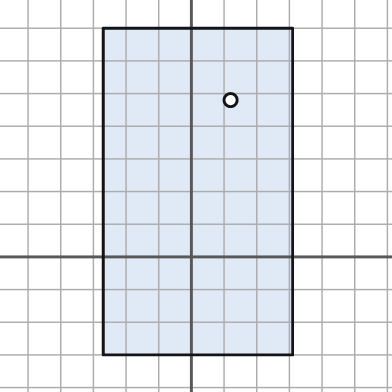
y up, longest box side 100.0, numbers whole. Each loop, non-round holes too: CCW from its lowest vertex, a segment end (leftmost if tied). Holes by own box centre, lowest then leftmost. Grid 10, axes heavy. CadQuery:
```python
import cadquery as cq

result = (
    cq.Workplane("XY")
    .moveTo(-27.0, -30.0)
    .lineTo(31.0, -30.0)
    .lineTo(31.0, 70.0)
    .lineTo(-27.0, 70.0)
    .close()
    .moveTo(12.0, 48.0)
    .circle(2.0)
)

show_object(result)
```